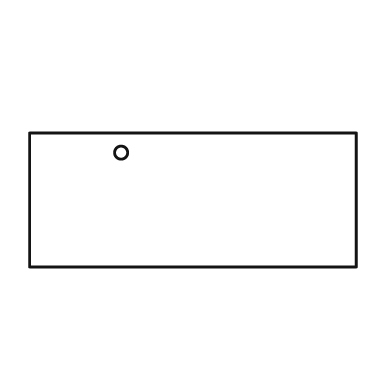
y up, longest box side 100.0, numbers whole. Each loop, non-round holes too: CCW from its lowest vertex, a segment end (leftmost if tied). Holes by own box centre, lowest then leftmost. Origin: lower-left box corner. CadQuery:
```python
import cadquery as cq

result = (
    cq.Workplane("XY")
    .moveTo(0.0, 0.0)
    .lineTo(100.0, 0.0)
    .lineTo(100.0, 41.0)
    .lineTo(0.0, 41.0)
    .close()
    .moveTo(28.0, 35.0)
    .circle(2.0)
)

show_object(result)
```